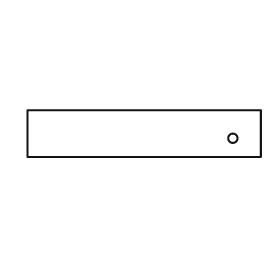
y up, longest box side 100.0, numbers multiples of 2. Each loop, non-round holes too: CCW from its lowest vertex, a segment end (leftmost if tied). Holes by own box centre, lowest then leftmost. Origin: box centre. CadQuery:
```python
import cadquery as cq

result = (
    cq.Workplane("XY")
    .moveTo(-50.0, -10.0)
    .lineTo(50.0, -10.0)
    .lineTo(50.0, 10.0)
    .lineTo(-50.0, 10.0)
    .close()
    .moveTo(38.0, -2.0)
    .circle(2.0)
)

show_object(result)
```